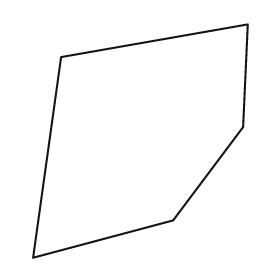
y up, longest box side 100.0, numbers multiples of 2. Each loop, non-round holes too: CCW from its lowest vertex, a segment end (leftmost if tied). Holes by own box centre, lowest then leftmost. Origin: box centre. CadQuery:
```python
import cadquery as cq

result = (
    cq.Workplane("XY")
    .moveTo(-46.0, -50.0)
    .lineTo(14.0, -34.0)
    .lineTo(44.0, 6.0)
    .lineTo(46.0, 50.0)
    .lineTo(-34.0, 36.0)
    .close()
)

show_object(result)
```